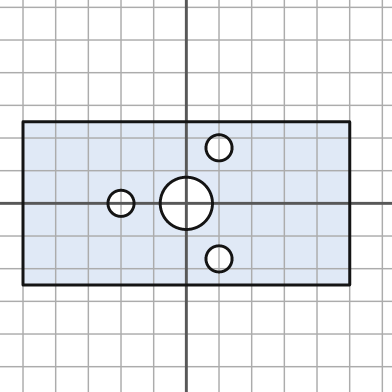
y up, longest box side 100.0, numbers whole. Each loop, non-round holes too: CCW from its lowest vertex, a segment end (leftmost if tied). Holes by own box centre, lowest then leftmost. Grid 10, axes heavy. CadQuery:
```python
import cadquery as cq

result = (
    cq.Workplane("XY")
    .moveTo(-50.0, -25.0)
    .lineTo(50.0, -25.0)
    .lineTo(50.0, 25.0)
    .lineTo(-50.0, 25.0)
    .close()
    .moveTo(10.0, -17.0)
    .circle(4.0)
    .moveTo(-20.0, 0.0)
    .circle(4.0)
    .moveTo(0.0, 0.0)
    .circle(8.0)
    .moveTo(10.0, 17.0)
    .circle(4.0)
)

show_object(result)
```